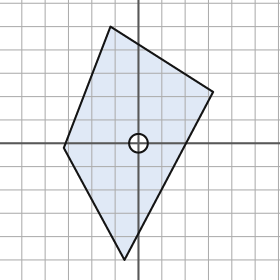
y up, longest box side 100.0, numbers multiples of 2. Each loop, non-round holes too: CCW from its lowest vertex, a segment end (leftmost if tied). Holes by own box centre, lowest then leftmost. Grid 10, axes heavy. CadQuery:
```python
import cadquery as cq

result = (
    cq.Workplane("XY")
    .moveTo(-6.0, -50.0)
    .lineTo(32.0, 22.0)
    .lineTo(-12.0, 50.0)
    .lineTo(-32.0, -2.0)
    .close()
    .moveTo(0.0, 0.0)
    .circle(4.0)
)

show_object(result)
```